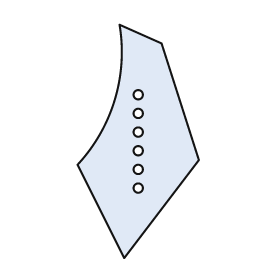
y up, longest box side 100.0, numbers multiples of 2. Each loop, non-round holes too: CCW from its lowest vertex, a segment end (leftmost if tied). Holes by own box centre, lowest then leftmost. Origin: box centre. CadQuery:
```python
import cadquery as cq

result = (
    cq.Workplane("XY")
    .moveTo(-6.0, -50.0)
    .lineTo(26.0, -8.0)
    .lineTo(10.0, 42.0)
    .lineTo(-8.0, 50.0)
    .threePointArc((-10.0, 18.0), (-26.0, -10.0))
    .close()
    .moveTo(0.0, -20.0)
    .circle(2.0)
    .moveTo(0.0, -12.0)
    .circle(2.0)
    .moveTo(0.0, -4.0)
    .circle(2.0)
    .moveTo(0.0, 4.0)
    .circle(2.0)
    .moveTo(0.0, 12.0)
    .circle(2.0)
    .moveTo(0.0, 20.0)
    .circle(2.0)
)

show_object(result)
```